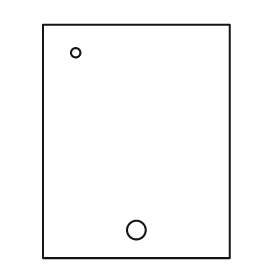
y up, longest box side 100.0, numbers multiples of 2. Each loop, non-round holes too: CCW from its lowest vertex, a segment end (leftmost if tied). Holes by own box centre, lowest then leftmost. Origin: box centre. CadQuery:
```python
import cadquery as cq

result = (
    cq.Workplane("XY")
    .moveTo(-40.0, -50.0)
    .lineTo(40.0, -50.0)
    .lineTo(40.0, 50.0)
    .lineTo(-40.0, 50.0)
    .close()
    .moveTo(0.0, -38.0)
    .circle(4.0)
    .moveTo(-26.0, 38.0)
    .circle(2.0)
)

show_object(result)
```